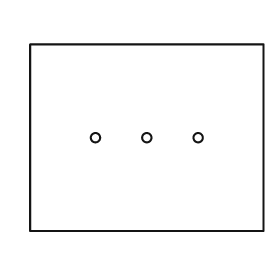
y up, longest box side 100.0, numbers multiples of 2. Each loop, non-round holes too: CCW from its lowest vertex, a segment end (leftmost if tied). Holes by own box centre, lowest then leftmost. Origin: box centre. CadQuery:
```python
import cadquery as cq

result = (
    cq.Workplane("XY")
    .moveTo(-50.0, -40.0)
    .lineTo(50.0, -40.0)
    .lineTo(50.0, 40.0)
    .lineTo(-50.0, 40.0)
    .close()
    .moveTo(-22.0, 0.0)
    .circle(2.0)
    .moveTo(0.0, 0.0)
    .circle(2.0)
    .moveTo(22.0, 0.0)
    .circle(2.0)
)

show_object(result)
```